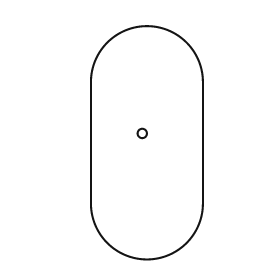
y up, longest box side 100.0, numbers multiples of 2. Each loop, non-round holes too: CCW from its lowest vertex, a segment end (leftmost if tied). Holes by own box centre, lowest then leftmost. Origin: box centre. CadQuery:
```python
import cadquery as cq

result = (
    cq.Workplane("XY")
    .moveTo(-24.0, -26.0)
    .threePointArc((0.0, -50.0), (24.0, -26.0))
    .lineTo(24.0, 26.0)
    .threePointArc((0.0, 50.0), (-24.0, 26.0))
    .close()
    .moveTo(-2.0, 4.0)
    .circle(2.0)
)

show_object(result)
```